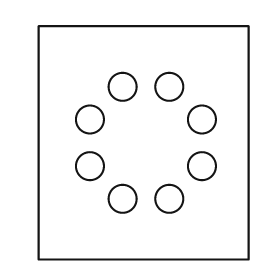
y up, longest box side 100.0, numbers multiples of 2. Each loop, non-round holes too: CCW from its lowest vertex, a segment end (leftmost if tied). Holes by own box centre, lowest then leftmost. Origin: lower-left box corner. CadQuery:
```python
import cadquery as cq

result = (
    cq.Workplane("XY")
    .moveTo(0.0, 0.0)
    .lineTo(90.0, 0.0)
    .lineTo(90.0, 100.0)
    .lineTo(0.0, 100.0)
    .close()
    .moveTo(36.0, 26.0)
    .circle(6.0)
    .moveTo(56.0, 26.0)
    .circle(6.0)
    .moveTo(22.0, 40.0)
    .circle(6.0)
    .moveTo(70.0, 40.0)
    .circle(6.0)
    .moveTo(22.0, 60.0)
    .circle(6.0)
    .moveTo(70.0, 60.0)
    .circle(6.0)
    .moveTo(36.0, 74.0)
    .circle(6.0)
    .moveTo(56.0, 74.0)
    .circle(6.0)
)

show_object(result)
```